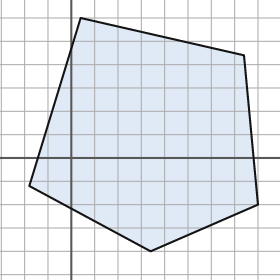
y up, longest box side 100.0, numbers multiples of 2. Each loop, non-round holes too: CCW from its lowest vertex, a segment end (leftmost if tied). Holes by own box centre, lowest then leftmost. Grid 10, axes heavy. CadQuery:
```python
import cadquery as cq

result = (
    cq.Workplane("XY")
    .moveTo(34.0, -40.0)
    .lineTo(80.0, -20.0)
    .lineTo(74.0, 44.0)
    .lineTo(4.0, 60.0)
    .lineTo(-18.0, -12.0)
    .close()
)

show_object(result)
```